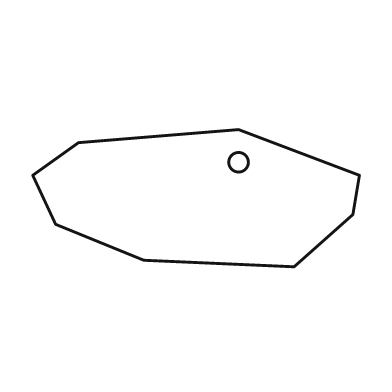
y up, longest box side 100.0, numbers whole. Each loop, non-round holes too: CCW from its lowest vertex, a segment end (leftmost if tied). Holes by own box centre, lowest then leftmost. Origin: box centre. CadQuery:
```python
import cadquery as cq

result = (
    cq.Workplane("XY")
    .moveTo(30.0, -21.0)
    .lineTo(48.0, -5.0)
    .lineTo(50.0, 7.0)
    .lineTo(13.0, 21.0)
    .lineTo(-36.0, 17.0)
    .lineTo(-50.0, 7.0)
    .lineTo(-43.0, -8.0)
    .lineTo(-16.0, -19.0)
    .close()
    .moveTo(13.0, 11.0)
    .circle(3.0)
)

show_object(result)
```